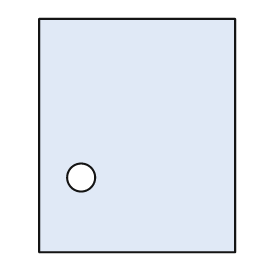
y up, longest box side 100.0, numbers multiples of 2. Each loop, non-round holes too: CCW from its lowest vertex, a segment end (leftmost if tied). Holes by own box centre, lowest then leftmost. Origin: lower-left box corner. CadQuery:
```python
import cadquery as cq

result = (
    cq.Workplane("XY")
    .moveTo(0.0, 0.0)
    .lineTo(84.0, 0.0)
    .lineTo(84.0, 100.0)
    .lineTo(0.0, 100.0)
    .close()
    .moveTo(18.0, 32.0)
    .circle(6.0)
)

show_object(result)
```